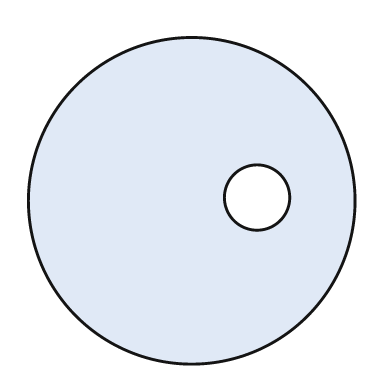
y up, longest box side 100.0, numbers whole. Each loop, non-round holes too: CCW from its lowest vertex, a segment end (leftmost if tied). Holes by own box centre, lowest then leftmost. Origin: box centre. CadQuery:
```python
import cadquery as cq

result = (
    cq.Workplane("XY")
    .moveTo(0.0, 0.0)
    .circle(50.0)
    .moveTo(20.0, 1.0)
    .circle(10.0)
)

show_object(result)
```